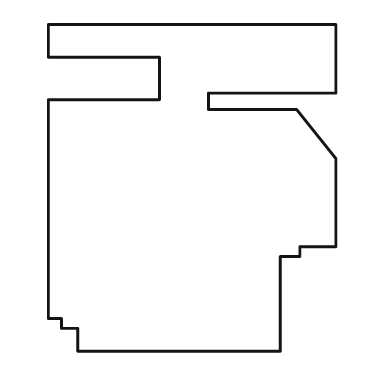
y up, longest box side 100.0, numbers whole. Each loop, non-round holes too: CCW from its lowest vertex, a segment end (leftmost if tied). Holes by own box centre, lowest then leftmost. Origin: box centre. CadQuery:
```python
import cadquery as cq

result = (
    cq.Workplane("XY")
    .moveTo(-35.0, -50.0)
    .lineTo(27.0, -50.0)
    .lineTo(27.0, -21.0)
    .lineTo(33.0, -21.0)
    .lineTo(33.0, -18.0)
    .lineTo(44.0, -18.0)
    .lineTo(44.0, 9.0)
    .lineTo(32.0, 24.0)
    .lineTo(5.0, 24.0)
    .lineTo(5.0, 29.0)
    .lineTo(44.0, 29.0)
    .lineTo(44.0, 50.0)
    .lineTo(-44.0, 50.0)
    .lineTo(-44.0, 40.0)
    .lineTo(-10.0, 40.0)
    .lineTo(-10.0, 27.0)
    .lineTo(-44.0, 27.0)
    .lineTo(-44.0, -40.0)
    .lineTo(-40.0, -40.0)
    .lineTo(-40.0, -43.0)
    .lineTo(-35.0, -43.0)
    .close()
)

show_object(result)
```